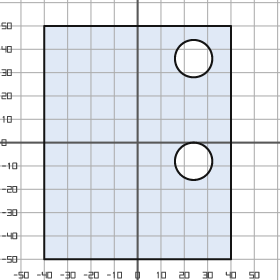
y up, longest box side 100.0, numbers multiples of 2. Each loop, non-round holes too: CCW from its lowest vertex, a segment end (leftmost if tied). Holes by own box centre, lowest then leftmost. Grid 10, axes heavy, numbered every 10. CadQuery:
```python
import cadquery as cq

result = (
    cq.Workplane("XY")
    .moveTo(-40.0, -50.0)
    .lineTo(40.0, -50.0)
    .lineTo(40.0, 50.0)
    .lineTo(-40.0, 50.0)
    .close()
    .moveTo(24.0, -8.0)
    .circle(8.0)
    .moveTo(24.0, 36.0)
    .circle(8.0)
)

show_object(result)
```